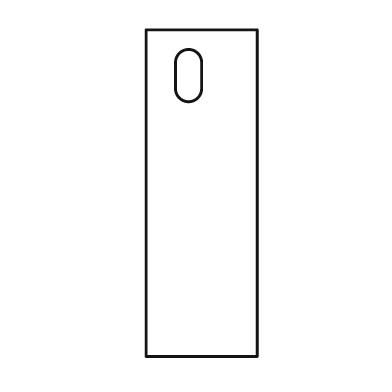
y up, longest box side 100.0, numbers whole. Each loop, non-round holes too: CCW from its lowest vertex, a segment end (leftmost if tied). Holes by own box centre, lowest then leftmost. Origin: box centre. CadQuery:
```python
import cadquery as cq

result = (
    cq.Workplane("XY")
    .moveTo(-17.0, -50.0)
    .lineTo(17.0, -50.0)
    .lineTo(17.0, 50.0)
    .lineTo(-17.0, 50.0)
    .close()
    .moveTo(-8.0, 32.0)
    .threePointArc((-4.0, 28.0), (0.0, 32.0))
    .lineTo(0.0, 40.0)
    .threePointArc((-4.0, 44.0), (-8.0, 40.0))
    .close()
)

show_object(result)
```